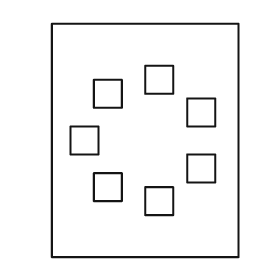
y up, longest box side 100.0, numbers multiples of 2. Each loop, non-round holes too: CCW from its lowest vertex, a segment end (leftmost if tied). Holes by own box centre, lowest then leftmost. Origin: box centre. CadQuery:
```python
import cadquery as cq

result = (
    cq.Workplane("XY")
    .moveTo(-40.0, -50.0)
    .lineTo(40.0, -50.0)
    .lineTo(40.0, 50.0)
    .lineTo(-40.0, 50.0)
    .close()
    .moveTo(0.0, -32.0)
    .lineTo(12.0, -32.0)
    .lineTo(12.0, -20.0)
    .lineTo(0.0, -20.0)
    .close()
    .moveTo(-22.0, -26.0)
    .lineTo(-10.0, -26.0)
    .lineTo(-10.0, -14.0)
    .lineTo(-22.0, -14.0)
    .close()
    .moveTo(18.0, -18.0)
    .lineTo(30.0, -18.0)
    .lineTo(30.0, -6.0)
    .lineTo(18.0, -6.0)
    .close()
    .moveTo(-32.0, -6.0)
    .lineTo(-20.0, -6.0)
    .lineTo(-20.0, 6.0)
    .lineTo(-32.0, 6.0)
    .close()
    .moveTo(18.0, 6.0)
    .lineTo(30.0, 6.0)
    .lineTo(30.0, 18.0)
    .lineTo(18.0, 18.0)
    .close()
    .moveTo(-22.0, 14.0)
    .lineTo(-10.0, 14.0)
    .lineTo(-10.0, 26.0)
    .lineTo(-22.0, 26.0)
    .close()
    .moveTo(0.0, 20.0)
    .lineTo(12.0, 20.0)
    .lineTo(12.0, 32.0)
    .lineTo(0.0, 32.0)
    .close()
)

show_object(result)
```